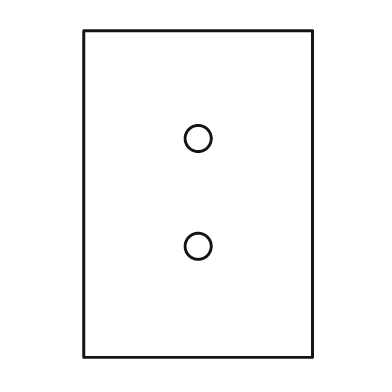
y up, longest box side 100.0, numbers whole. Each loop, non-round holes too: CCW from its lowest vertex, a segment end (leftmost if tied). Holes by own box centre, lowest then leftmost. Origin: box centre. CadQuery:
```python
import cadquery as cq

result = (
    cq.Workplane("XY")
    .moveTo(-35.0, -50.0)
    .lineTo(35.0, -50.0)
    .lineTo(35.0, 50.0)
    .lineTo(-35.0, 50.0)
    .close()
    .moveTo(0.0, -16.0)
    .circle(4.0)
    .moveTo(0.0, 17.0)
    .circle(4.0)
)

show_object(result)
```